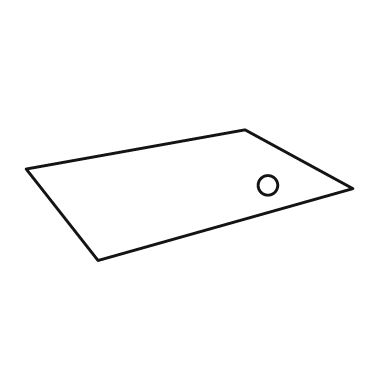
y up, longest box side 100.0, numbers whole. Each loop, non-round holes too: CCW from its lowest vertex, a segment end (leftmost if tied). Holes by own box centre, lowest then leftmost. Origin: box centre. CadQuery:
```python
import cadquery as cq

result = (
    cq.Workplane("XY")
    .moveTo(-28.0, -20.0)
    .lineTo(50.0, 2.0)
    .lineTo(17.0, 20.0)
    .lineTo(-50.0, 8.0)
    .close()
    .moveTo(24.0, 3.0)
    .circle(3.0)
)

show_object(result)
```